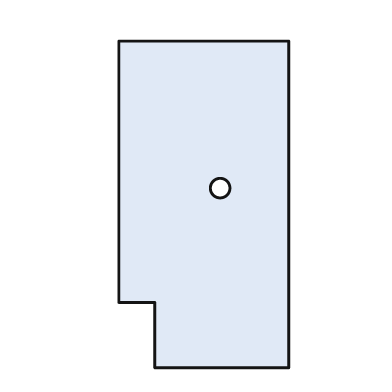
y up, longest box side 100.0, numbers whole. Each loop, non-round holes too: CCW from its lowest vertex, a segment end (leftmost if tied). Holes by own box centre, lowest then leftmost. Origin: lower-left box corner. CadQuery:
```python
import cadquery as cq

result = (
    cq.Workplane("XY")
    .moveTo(11.0, 0.0)
    .lineTo(52.0, 0.0)
    .lineTo(52.0, 100.0)
    .lineTo(0.0, 100.0)
    .lineTo(0.0, 20.0)
    .lineTo(11.0, 20.0)
    .close()
    .moveTo(31.0, 55.0)
    .circle(3.0)
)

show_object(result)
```